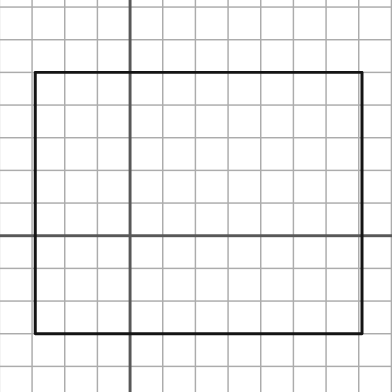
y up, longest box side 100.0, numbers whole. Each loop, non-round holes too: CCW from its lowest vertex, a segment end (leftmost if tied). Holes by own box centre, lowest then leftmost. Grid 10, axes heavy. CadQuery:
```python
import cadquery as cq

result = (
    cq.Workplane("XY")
    .moveTo(-29.0, -30.0)
    .lineTo(71.0, -30.0)
    .lineTo(71.0, 50.0)
    .lineTo(-29.0, 50.0)
    .close()
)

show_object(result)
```